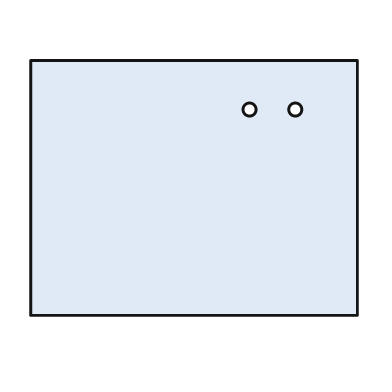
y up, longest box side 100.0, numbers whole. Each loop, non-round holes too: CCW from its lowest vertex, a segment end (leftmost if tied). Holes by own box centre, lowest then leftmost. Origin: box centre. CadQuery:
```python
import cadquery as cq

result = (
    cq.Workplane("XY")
    .moveTo(-50.0, -39.0)
    .lineTo(50.0, -39.0)
    .lineTo(50.0, 39.0)
    .lineTo(-50.0, 39.0)
    .close()
    .moveTo(17.0, 24.0)
    .circle(2.0)
    .moveTo(31.0, 24.0)
    .circle(2.0)
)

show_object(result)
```